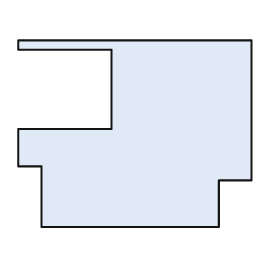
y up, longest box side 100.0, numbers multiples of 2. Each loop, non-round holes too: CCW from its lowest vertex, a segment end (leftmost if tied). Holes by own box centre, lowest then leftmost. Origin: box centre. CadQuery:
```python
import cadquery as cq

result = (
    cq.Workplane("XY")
    .moveTo(-40.0, -40.0)
    .lineTo(36.0, -40.0)
    .lineTo(36.0, -20.0)
    .lineTo(50.0, -20.0)
    .lineTo(50.0, 40.0)
    .lineTo(-50.0, 40.0)
    .lineTo(-50.0, 36.0)
    .lineTo(-10.0, 36.0)
    .lineTo(-10.0, 2.0)
    .lineTo(-50.0, 2.0)
    .lineTo(-50.0, -14.0)
    .lineTo(-40.0, -14.0)
    .close()
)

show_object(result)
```